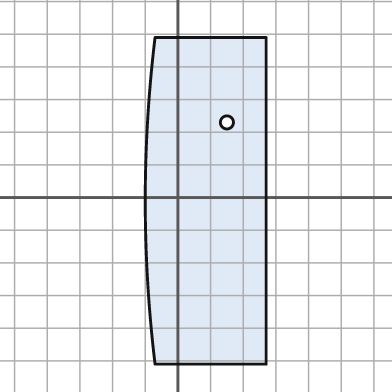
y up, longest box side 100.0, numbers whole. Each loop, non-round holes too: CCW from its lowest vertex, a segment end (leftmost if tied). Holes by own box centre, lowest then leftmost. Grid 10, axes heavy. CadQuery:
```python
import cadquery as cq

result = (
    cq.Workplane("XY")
    .moveTo(-7.0, -51.0)
    .lineTo(27.0, -51.0)
    .lineTo(27.0, 49.0)
    .lineTo(-7.0, 49.0)
    .threePointArc((-10.0, -1.0), (-7.0, -51.0))
    .close()
    .moveTo(15.0, 23.0)
    .circle(2.0)
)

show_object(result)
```